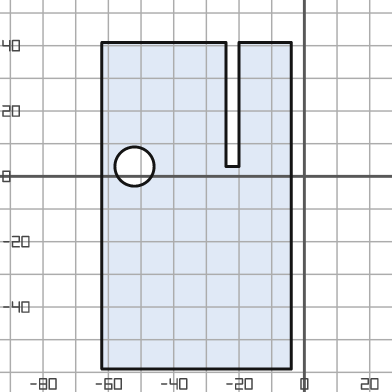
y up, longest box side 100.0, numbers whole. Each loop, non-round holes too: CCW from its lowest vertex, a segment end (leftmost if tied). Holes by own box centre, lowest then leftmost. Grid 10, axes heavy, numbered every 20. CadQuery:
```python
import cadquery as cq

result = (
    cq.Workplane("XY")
    .moveTo(-62.0, -59.0)
    .lineTo(-4.0, -59.0)
    .lineTo(-4.0, 41.0)
    .lineTo(-20.0, 41.0)
    .lineTo(-20.0, 3.0)
    .lineTo(-24.0, 3.0)
    .lineTo(-24.0, 41.0)
    .lineTo(-62.0, 41.0)
    .close()
    .moveTo(-52.0, 3.0)
    .circle(6.0)
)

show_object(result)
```